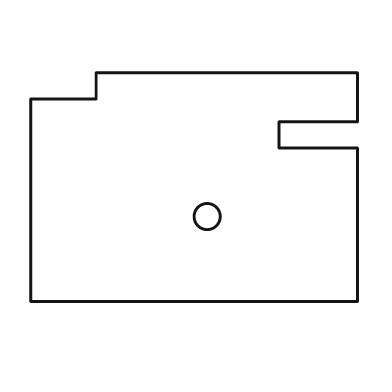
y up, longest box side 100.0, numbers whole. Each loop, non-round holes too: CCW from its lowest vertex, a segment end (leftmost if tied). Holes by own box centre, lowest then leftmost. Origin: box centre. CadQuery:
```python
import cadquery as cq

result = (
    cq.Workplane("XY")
    .moveTo(-50.0, -35.0)
    .lineTo(50.0, -35.0)
    .lineTo(50.0, 12.0)
    .lineTo(26.0, 12.0)
    .lineTo(26.0, 20.0)
    .lineTo(50.0, 20.0)
    .lineTo(50.0, 35.0)
    .lineTo(-30.0, 35.0)
    .lineTo(-30.0, 27.0)
    .lineTo(-50.0, 27.0)
    .close()
    .moveTo(4.0, -9.0)
    .circle(4.0)
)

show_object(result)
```